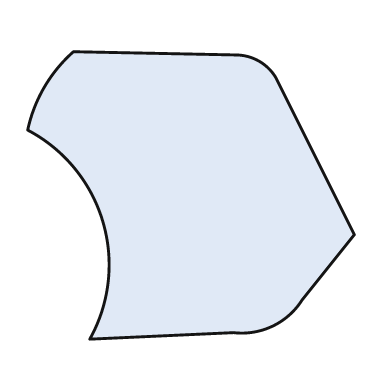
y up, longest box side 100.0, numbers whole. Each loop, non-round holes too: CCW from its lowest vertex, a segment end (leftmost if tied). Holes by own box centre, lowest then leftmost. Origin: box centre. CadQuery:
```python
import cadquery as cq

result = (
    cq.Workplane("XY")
    .moveTo(-31.0, -44.0)
    .lineTo(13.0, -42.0)
    .threePointArc((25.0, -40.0), (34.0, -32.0))
    .lineTo(50.0, -12.0)
    .lineTo(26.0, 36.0)
    .threePointArc((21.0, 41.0), (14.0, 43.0))
    .lineTo(-36.0, 44.0)
    .threePointArc((-45.0, 33.0), (-50.0, 20.0))
    .threePointArc((-27.0, -8.0), (-31.0, -44.0))
    .close()
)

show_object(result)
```